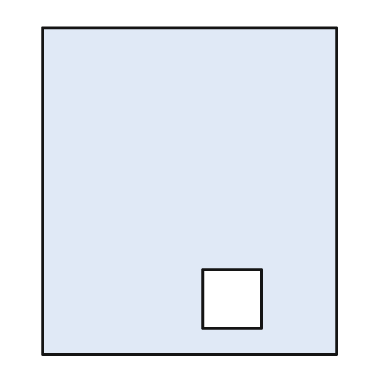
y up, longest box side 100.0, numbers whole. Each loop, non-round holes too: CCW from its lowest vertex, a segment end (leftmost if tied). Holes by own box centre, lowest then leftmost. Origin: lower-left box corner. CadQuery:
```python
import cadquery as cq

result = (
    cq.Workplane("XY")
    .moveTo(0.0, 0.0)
    .lineTo(90.0, 0.0)
    .lineTo(90.0, 100.0)
    .lineTo(0.0, 100.0)
    .close()
    .moveTo(49.0, 8.0)
    .lineTo(67.0, 8.0)
    .lineTo(67.0, 26.0)
    .lineTo(49.0, 26.0)
    .close()
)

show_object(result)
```